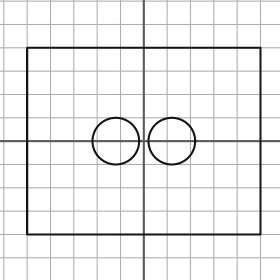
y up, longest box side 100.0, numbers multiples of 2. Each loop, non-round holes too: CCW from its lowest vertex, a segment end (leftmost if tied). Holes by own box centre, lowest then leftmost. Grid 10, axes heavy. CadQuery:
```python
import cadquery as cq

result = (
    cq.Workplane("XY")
    .moveTo(-50.0, -40.0)
    .lineTo(50.0, -40.0)
    .lineTo(50.0, 40.0)
    .lineTo(-50.0, 40.0)
    .close()
    .moveTo(-12.0, 0.0)
    .circle(10.0)
    .moveTo(12.0, 0.0)
    .circle(10.0)
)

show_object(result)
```